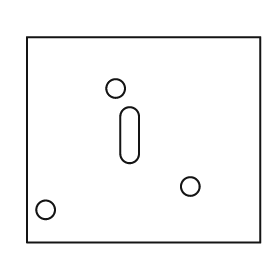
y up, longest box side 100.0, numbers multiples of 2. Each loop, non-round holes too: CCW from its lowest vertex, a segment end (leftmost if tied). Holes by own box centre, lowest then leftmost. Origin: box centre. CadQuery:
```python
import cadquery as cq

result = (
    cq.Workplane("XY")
    .moveTo(-50.0, -44.0)
    .lineTo(50.0, -44.0)
    .lineTo(50.0, 44.0)
    .lineTo(-50.0, 44.0)
    .close()
    .moveTo(-42.0, -30.0)
    .circle(4.0)
    .moveTo(20.0, -20.0)
    .circle(4.0)
    .moveTo(-10.0, -6.0)
    .threePointArc((-6.0, -10.0), (-2.0, -6.0))
    .lineTo(-2.0, 10.0)
    .threePointArc((-6.0, 14.0), (-10.0, 10.0))
    .close()
    .moveTo(-12.0, 22.0)
    .circle(4.0)
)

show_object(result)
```